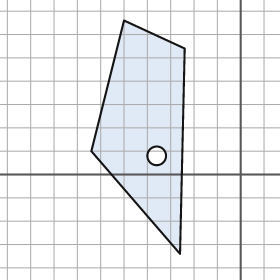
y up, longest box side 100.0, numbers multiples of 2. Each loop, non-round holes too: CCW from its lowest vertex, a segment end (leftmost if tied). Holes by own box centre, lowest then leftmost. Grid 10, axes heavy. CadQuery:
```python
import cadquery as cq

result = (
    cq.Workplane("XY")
    .moveTo(-26.0, -34.0)
    .lineTo(-24.0, 54.0)
    .lineTo(-50.0, 66.0)
    .lineTo(-64.0, 10.0)
    .close()
    .moveTo(-36.0, 8.0)
    .circle(4.0)
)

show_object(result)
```